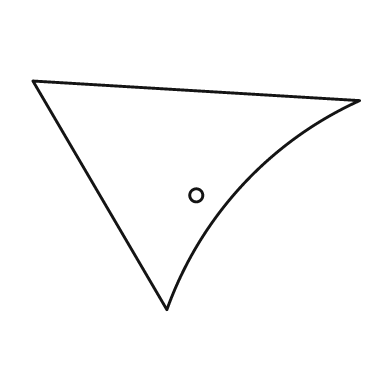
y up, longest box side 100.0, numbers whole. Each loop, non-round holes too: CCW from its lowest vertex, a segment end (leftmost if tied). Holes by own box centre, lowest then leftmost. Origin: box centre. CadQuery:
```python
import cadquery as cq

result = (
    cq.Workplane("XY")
    .moveTo(-9.0, -35.0)
    .threePointArc((14.0, 3.0), (50.0, 29.0))
    .lineTo(-50.0, 35.0)
    .close()
    .moveTo(0.0, 0.0)
    .circle(2.0)
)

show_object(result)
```